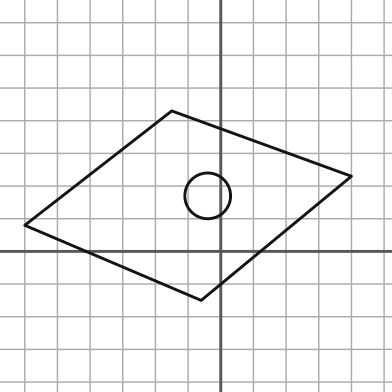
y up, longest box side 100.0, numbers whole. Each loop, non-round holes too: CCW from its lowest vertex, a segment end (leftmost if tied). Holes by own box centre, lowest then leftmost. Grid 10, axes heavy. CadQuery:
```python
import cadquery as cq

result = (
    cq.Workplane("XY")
    .moveTo(-6.0, -15.0)
    .lineTo(40.0, 23.0)
    .lineTo(-15.0, 43.0)
    .lineTo(-60.0, 8.0)
    .close()
    .moveTo(-4.0, 17.0)
    .circle(7.0)
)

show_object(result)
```